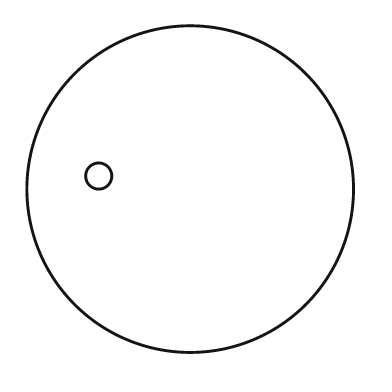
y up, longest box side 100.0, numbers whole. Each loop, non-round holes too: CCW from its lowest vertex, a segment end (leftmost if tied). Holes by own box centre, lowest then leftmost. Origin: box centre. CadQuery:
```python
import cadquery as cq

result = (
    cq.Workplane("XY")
    .moveTo(0.0, 0.0)
    .circle(50.0)
    .moveTo(-28.0, 4.0)
    .circle(4.0)
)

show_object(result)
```